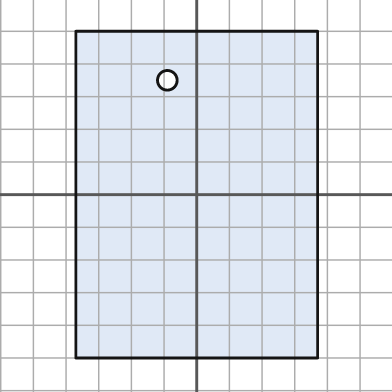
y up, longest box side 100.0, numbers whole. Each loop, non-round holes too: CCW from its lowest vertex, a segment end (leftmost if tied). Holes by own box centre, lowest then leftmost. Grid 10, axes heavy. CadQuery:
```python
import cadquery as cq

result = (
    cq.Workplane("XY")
    .moveTo(-37.0, -50.0)
    .lineTo(37.0, -50.0)
    .lineTo(37.0, 50.0)
    .lineTo(-37.0, 50.0)
    .close()
    .moveTo(-9.0, 35.0)
    .circle(3.0)
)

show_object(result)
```